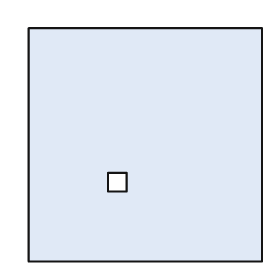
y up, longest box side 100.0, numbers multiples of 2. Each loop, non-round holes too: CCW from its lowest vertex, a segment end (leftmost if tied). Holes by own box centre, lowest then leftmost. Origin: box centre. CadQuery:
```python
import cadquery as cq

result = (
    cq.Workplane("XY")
    .moveTo(-50.0, -50.0)
    .lineTo(50.0, -50.0)
    .lineTo(50.0, 50.0)
    .lineTo(-50.0, 50.0)
    .close()
    .moveTo(-16.0, -20.0)
    .lineTo(-8.0, -20.0)
    .lineTo(-8.0, -12.0)
    .lineTo(-16.0, -12.0)
    .close()
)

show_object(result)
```